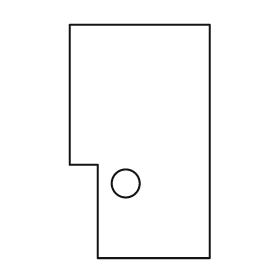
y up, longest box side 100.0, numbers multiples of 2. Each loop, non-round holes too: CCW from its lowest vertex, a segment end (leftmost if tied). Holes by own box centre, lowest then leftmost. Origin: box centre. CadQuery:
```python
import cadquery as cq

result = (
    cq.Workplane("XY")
    .moveTo(-18.0, -50.0)
    .lineTo(30.0, -50.0)
    .lineTo(30.0, 50.0)
    .lineTo(-30.0, 50.0)
    .lineTo(-30.0, -10.0)
    .lineTo(-18.0, -10.0)
    .close()
    .moveTo(-6.0, -18.0)
    .circle(6.0)
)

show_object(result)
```